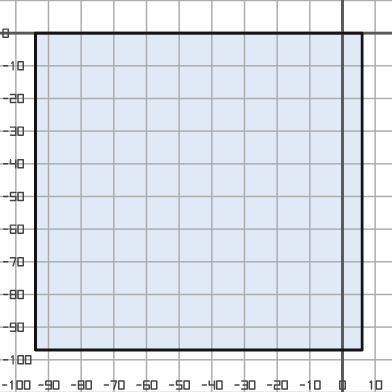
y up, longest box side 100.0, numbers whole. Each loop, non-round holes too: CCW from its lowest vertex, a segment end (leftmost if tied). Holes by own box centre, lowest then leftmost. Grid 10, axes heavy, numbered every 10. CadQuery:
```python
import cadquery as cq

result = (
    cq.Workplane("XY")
    .moveTo(-94.0, -97.0)
    .lineTo(6.0, -97.0)
    .lineTo(6.0, 0.0)
    .lineTo(-94.0, 0.0)
    .close()
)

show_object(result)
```